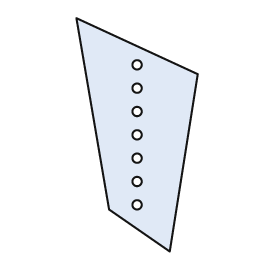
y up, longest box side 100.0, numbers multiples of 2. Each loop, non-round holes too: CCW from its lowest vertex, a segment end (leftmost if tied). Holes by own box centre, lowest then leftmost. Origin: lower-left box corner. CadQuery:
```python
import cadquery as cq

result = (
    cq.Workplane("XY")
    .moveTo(40.0, 0.0)
    .lineTo(52.0, 76.0)
    .lineTo(0.0, 100.0)
    .lineTo(14.0, 18.0)
    .close()
    .moveTo(26.0, 20.0)
    .circle(2.0)
    .moveTo(26.0, 30.0)
    .circle(2.0)
    .moveTo(26.0, 40.0)
    .circle(2.0)
    .moveTo(26.0, 50.0)
    .circle(2.0)
    .moveTo(26.0, 60.0)
    .circle(2.0)
    .moveTo(26.0, 70.0)
    .circle(2.0)
    .moveTo(26.0, 80.0)
    .circle(2.0)
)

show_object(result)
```